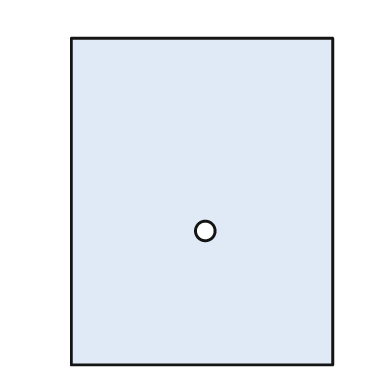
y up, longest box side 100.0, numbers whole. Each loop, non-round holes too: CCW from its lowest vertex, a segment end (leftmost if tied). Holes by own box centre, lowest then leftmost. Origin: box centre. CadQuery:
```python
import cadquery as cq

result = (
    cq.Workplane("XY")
    .moveTo(-40.0, -50.0)
    .lineTo(40.0, -50.0)
    .lineTo(40.0, 50.0)
    .lineTo(-40.0, 50.0)
    .close()
    .moveTo(1.0, -9.0)
    .circle(3.0)
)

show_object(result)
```